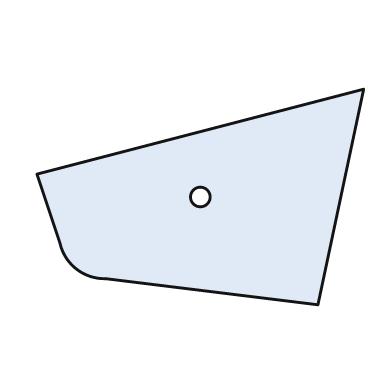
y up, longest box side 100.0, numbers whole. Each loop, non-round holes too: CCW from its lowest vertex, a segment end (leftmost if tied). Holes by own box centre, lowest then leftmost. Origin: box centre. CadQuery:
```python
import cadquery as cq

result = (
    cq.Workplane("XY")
    .moveTo(36.0, -33.0)
    .lineTo(50.0, 33.0)
    .lineTo(-50.0, 7.0)
    .lineTo(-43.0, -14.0)
    .threePointArc((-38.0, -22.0), (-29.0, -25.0))
    .close()
    .moveTo(0.0, 0.0)
    .circle(3.0)
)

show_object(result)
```